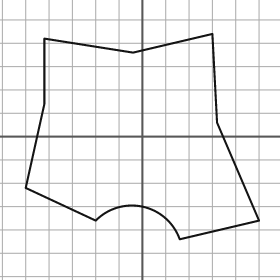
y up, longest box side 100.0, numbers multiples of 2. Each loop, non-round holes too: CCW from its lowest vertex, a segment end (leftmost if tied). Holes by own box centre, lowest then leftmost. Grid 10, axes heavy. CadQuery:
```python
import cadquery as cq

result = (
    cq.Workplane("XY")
    .moveTo(16.0, -44.0)
    .lineTo(50.0, -36.0)
    .lineTo(32.0, 6.0)
    .lineTo(30.0, 44.0)
    .lineTo(-4.0, 36.0)
    .lineTo(-42.0, 42.0)
    .lineTo(-42.0, 14.0)
    .lineTo(-50.0, -22.0)
    .lineTo(-20.0, -36.0)
    .threePointArc((0.0, -30.0), (16.0, -44.0))
    .close()
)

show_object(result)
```